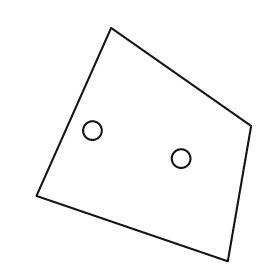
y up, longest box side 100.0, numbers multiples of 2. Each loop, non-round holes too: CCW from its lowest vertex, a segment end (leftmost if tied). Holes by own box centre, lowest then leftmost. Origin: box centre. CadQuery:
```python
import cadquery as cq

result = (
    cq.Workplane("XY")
    .moveTo(36.0, -50.0)
    .lineTo(46.0, 8.0)
    .lineTo(-14.0, 50.0)
    .lineTo(-46.0, -22.0)
    .close()
    .moveTo(16.0, -6.0)
    .circle(4.0)
    .moveTo(-22.0, 6.0)
    .circle(4.0)
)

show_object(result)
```